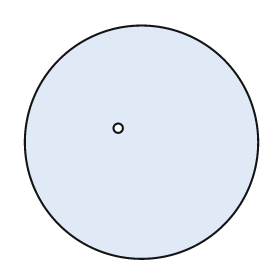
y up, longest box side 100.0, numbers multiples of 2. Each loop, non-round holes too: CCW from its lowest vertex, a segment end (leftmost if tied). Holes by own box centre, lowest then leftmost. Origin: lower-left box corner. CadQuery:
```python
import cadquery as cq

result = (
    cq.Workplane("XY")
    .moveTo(50.0, 50.0)
    .circle(50.0)
    .moveTo(40.0, 56.0)
    .circle(2.0)
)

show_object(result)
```